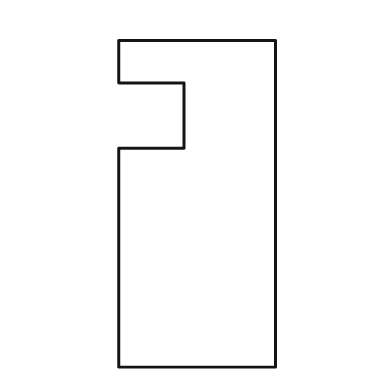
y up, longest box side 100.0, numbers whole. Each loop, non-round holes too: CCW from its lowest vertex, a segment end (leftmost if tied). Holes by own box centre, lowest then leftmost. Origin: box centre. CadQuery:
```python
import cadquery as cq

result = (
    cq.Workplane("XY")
    .moveTo(-24.0, -50.0)
    .lineTo(24.0, -50.0)
    .lineTo(24.0, 50.0)
    .lineTo(-24.0, 50.0)
    .lineTo(-24.0, 37.0)
    .lineTo(-4.0, 37.0)
    .lineTo(-4.0, 17.0)
    .lineTo(-24.0, 17.0)
    .close()
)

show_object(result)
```